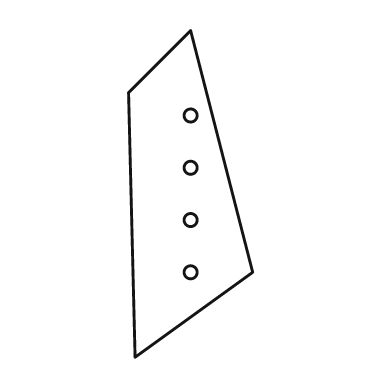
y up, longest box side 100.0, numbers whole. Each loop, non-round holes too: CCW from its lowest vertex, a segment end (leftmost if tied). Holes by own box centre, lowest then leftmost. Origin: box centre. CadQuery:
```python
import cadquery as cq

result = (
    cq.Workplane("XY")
    .moveTo(-17.0, -50.0)
    .lineTo(19.0, -24.0)
    .lineTo(0.0, 50.0)
    .lineTo(-19.0, 31.0)
    .close()
    .moveTo(0.0, -24.0)
    .circle(2.0)
    .moveTo(0.0, -8.0)
    .circle(2.0)
    .moveTo(0.0, 8.0)
    .circle(2.0)
    .moveTo(0.0, 24.0)
    .circle(2.0)
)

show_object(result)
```